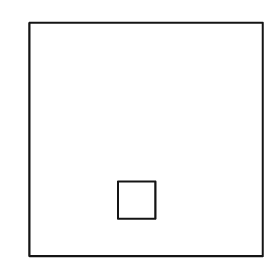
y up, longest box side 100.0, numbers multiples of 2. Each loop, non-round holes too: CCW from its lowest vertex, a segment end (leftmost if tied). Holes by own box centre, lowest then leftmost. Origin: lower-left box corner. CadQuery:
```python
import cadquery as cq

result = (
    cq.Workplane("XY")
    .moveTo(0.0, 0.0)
    .lineTo(100.0, 0.0)
    .lineTo(100.0, 100.0)
    .lineTo(0.0, 100.0)
    .close()
    .moveTo(38.0, 16.0)
    .lineTo(54.0, 16.0)
    .lineTo(54.0, 32.0)
    .lineTo(38.0, 32.0)
    .close()
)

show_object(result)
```